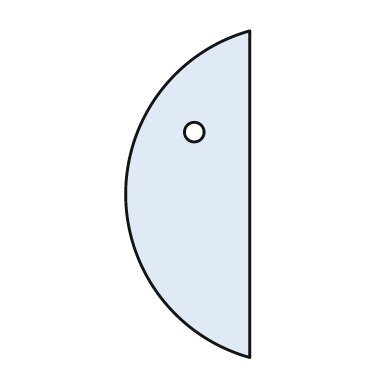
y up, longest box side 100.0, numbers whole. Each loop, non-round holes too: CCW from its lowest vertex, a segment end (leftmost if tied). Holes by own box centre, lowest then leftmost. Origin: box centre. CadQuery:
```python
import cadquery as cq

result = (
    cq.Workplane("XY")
    .moveTo(19.0, -50.0)
    .lineTo(19.0, 50.0)
    .threePointArc((-19.0, 0.0), (19.0, -50.0))
    .close()
    .moveTo(2.0, 19.0)
    .circle(3.0)
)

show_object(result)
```